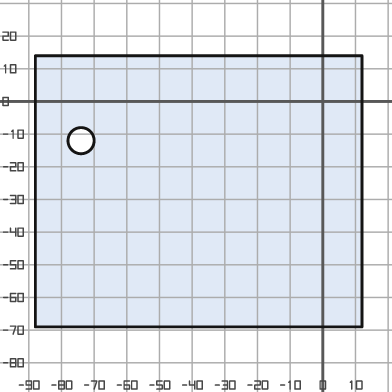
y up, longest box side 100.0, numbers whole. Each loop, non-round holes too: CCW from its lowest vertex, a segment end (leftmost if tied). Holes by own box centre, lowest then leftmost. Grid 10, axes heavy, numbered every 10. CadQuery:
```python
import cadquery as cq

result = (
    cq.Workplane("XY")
    .moveTo(-88.0, -69.0)
    .lineTo(12.0, -69.0)
    .lineTo(12.0, 14.0)
    .lineTo(-88.0, 14.0)
    .close()
    .moveTo(-74.0, -12.0)
    .circle(4.0)
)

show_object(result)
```